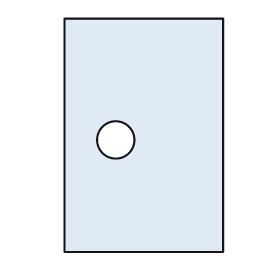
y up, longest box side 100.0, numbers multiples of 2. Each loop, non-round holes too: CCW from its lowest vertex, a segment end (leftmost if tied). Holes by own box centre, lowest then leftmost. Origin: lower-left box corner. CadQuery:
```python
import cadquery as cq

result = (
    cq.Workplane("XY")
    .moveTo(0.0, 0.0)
    .lineTo(68.0, 0.0)
    .lineTo(68.0, 100.0)
    .lineTo(0.0, 100.0)
    .close()
    .moveTo(22.0, 48.0)
    .circle(8.0)
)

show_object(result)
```